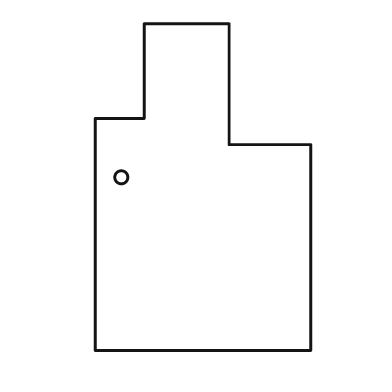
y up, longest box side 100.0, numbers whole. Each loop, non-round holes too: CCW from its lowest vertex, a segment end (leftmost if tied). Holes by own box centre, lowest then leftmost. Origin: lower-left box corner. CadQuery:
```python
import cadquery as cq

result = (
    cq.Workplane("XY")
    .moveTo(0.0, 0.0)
    .lineTo(66.0, 0.0)
    .lineTo(66.0, 63.0)
    .lineTo(41.0, 63.0)
    .lineTo(41.0, 100.0)
    .lineTo(15.0, 100.0)
    .lineTo(15.0, 71.0)
    .lineTo(0.0, 71.0)
    .close()
    .moveTo(8.0, 53.0)
    .circle(2.0)
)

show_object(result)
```